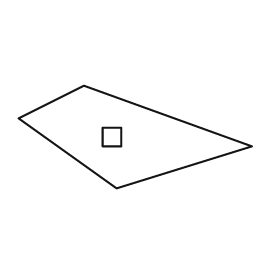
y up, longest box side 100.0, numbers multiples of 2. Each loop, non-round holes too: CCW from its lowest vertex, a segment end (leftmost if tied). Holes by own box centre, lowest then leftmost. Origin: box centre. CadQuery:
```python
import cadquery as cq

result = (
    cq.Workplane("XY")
    .moveTo(-8.0, -22.0)
    .lineTo(50.0, -4.0)
    .lineTo(-22.0, 22.0)
    .lineTo(-50.0, 8.0)
    .close()
    .moveTo(-14.0, -4.0)
    .lineTo(-6.0, -4.0)
    .lineTo(-6.0, 4.0)
    .lineTo(-14.0, 4.0)
    .close()
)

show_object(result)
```